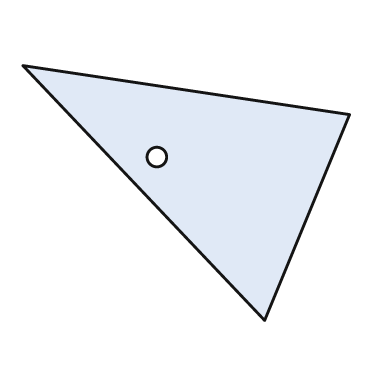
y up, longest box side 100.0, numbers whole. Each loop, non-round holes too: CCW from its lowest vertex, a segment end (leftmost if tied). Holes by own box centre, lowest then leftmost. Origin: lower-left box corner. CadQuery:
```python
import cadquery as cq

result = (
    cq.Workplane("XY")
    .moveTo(74.0, 0.0)
    .lineTo(100.0, 63.0)
    .lineTo(0.0, 78.0)
    .close()
    .moveTo(41.0, 50.0)
    .circle(3.0)
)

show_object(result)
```